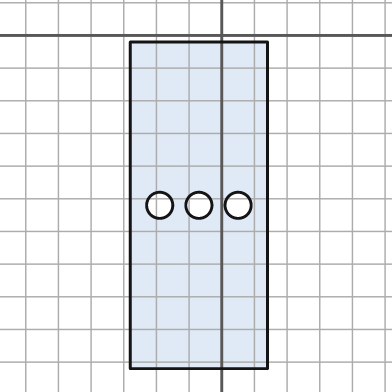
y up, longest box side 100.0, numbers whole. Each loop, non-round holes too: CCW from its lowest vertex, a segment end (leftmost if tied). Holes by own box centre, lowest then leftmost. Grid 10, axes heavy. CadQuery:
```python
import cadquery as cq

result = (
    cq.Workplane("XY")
    .moveTo(-28.0, -102.0)
    .lineTo(14.0, -102.0)
    .lineTo(14.0, -2.0)
    .lineTo(-28.0, -2.0)
    .close()
    .moveTo(-19.0, -52.0)
    .circle(4.0)
    .moveTo(-7.0, -52.0)
    .circle(4.0)
    .moveTo(5.0, -52.0)
    .circle(4.0)
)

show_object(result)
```